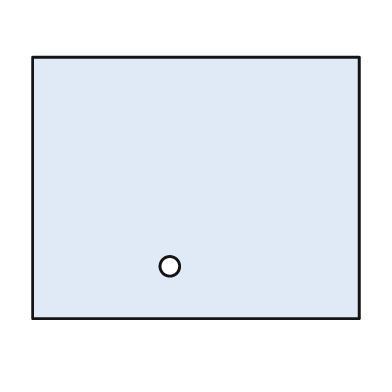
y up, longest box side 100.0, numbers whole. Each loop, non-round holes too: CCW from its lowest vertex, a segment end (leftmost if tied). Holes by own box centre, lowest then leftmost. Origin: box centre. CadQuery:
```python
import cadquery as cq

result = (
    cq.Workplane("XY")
    .moveTo(-50.0, -40.0)
    .lineTo(50.0, -40.0)
    .lineTo(50.0, 40.0)
    .lineTo(-50.0, 40.0)
    .close()
    .moveTo(-8.0, -24.0)
    .circle(3.0)
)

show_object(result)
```